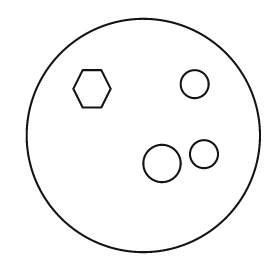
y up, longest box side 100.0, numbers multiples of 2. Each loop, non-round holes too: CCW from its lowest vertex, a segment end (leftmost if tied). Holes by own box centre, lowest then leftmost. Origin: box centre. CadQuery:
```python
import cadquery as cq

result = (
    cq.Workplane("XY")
    .moveTo(0.0, 0.0)
    .circle(50.0)
    .moveTo(8.0, -12.0)
    .circle(8.0)
    .moveTo(26.0, -8.0)
    .circle(6.0)
    .moveTo(-26.0, 12.0)
    .lineTo(-18.0, 12.0)
    .lineTo(-14.0, 20.0)
    .lineTo(-18.0, 28.0)
    .lineTo(-26.0, 28.0)
    .lineTo(-30.0, 20.0)
    .close()
    .moveTo(22.0, 22.0)
    .circle(6.0)
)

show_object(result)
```